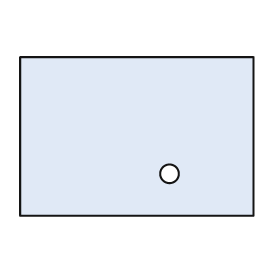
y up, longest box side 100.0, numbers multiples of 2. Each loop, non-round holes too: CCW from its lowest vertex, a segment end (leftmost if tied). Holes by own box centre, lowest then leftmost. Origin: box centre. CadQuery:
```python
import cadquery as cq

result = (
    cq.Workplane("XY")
    .moveTo(-50.0, -34.0)
    .lineTo(50.0, -34.0)
    .lineTo(50.0, 34.0)
    .lineTo(-50.0, 34.0)
    .close()
    .moveTo(14.0, -16.0)
    .circle(4.0)
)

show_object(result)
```